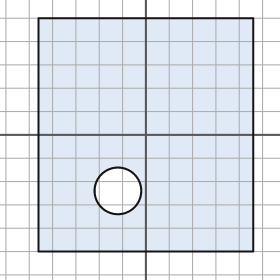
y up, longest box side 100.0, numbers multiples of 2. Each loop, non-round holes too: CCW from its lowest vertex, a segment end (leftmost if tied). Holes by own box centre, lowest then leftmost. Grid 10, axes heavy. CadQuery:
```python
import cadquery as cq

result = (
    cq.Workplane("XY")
    .moveTo(-46.0, -50.0)
    .lineTo(46.0, -50.0)
    .lineTo(46.0, 50.0)
    .lineTo(-46.0, 50.0)
    .close()
    .moveTo(-12.0, -24.0)
    .circle(10.0)
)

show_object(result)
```